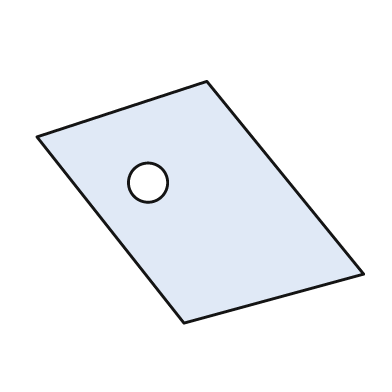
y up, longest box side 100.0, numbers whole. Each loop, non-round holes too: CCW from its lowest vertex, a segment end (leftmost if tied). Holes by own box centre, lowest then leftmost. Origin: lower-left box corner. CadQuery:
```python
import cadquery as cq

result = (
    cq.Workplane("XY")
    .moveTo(45.0, 0.0)
    .lineTo(100.0, 15.0)
    .lineTo(52.0, 74.0)
    .lineTo(0.0, 57.0)
    .close()
    .moveTo(34.0, 43.0)
    .circle(6.0)
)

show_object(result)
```